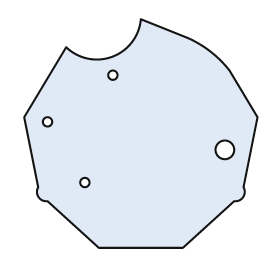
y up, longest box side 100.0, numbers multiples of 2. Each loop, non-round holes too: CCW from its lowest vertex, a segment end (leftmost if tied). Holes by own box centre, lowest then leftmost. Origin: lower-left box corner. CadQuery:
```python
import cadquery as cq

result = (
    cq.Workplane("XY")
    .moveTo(32.0, 0.0)
    .lineTo(68.0, 0.0)
    .lineTo(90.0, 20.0)
    .threePointArc((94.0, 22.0), (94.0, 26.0))
    .lineTo(100.0, 56.0)
    .lineTo(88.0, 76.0)
    .threePointArc((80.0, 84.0), (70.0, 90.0))
    .lineTo(50.0, 98.0)
    .threePointArc((38.0, 82.0), (18.0, 86.0))
    .lineTo(0.0, 56.0)
    .lineTo(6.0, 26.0)
    .threePointArc((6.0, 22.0), (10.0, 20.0))
    .close()
    .moveTo(26.0, 28.0)
    .circle(2.0)
    .moveTo(86.0, 42.0)
    .circle(4.0)
    .moveTo(10.0, 54.0)
    .circle(2.0)
    .moveTo(38.0, 74.0)
    .circle(2.0)
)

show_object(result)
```